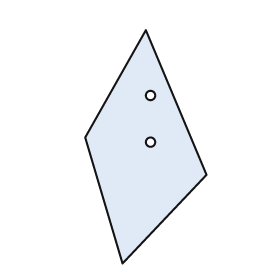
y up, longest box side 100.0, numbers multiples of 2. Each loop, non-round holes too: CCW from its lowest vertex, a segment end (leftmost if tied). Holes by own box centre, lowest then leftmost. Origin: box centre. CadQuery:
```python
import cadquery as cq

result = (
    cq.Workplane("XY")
    .moveTo(-10.0, -50.0)
    .lineTo(26.0, -12.0)
    .lineTo(0.0, 50.0)
    .lineTo(-26.0, 4.0)
    .close()
    .moveTo(2.0, 2.0)
    .circle(2.0)
    .moveTo(2.0, 22.0)
    .circle(2.0)
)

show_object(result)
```